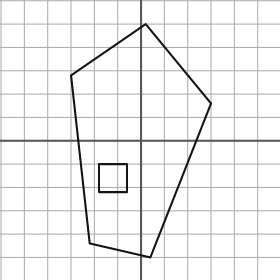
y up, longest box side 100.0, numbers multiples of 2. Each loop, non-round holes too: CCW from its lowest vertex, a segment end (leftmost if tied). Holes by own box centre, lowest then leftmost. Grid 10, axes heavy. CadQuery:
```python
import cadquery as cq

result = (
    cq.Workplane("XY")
    .moveTo(4.0, -50.0)
    .lineTo(30.0, 16.0)
    .lineTo(2.0, 50.0)
    .lineTo(-30.0, 28.0)
    .lineTo(-22.0, -44.0)
    .close()
    .moveTo(-18.0, -22.0)
    .lineTo(-6.0, -22.0)
    .lineTo(-6.0, -10.0)
    .lineTo(-18.0, -10.0)
    .close()
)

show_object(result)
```